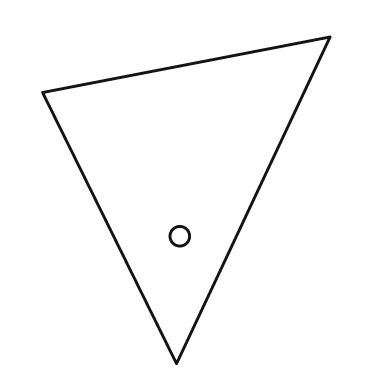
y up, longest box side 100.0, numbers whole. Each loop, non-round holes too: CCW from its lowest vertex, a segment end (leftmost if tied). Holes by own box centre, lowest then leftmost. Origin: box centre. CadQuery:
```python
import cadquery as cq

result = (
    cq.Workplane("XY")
    .moveTo(-3.0, -50.0)
    .lineTo(44.0, 50.0)
    .lineTo(-44.0, 33.0)
    .close()
    .moveTo(-2.0, -11.0)
    .circle(3.0)
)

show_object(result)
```